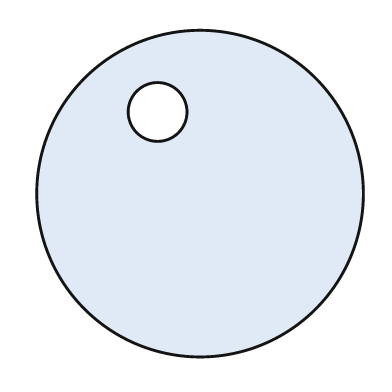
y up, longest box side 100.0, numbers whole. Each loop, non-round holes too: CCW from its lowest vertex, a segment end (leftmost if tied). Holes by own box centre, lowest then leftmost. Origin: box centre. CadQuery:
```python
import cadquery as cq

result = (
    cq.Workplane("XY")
    .moveTo(0.0, 0.0)
    .circle(50.0)
    .moveTo(-13.0, 25.0)
    .circle(9.0)
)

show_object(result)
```